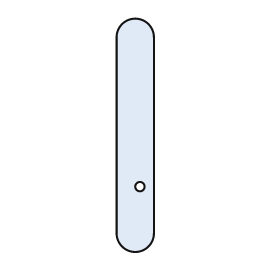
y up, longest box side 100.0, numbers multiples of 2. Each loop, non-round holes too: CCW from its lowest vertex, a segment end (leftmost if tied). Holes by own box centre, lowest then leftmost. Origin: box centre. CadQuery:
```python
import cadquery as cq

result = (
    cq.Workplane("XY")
    .moveTo(-8.0, -42.0)
    .threePointArc((0.0, -50.0), (8.0, -42.0))
    .lineTo(8.0, 42.0)
    .threePointArc((0.0, 50.0), (-8.0, 42.0))
    .close()
    .moveTo(2.0, -22.0)
    .circle(2.0)
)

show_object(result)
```